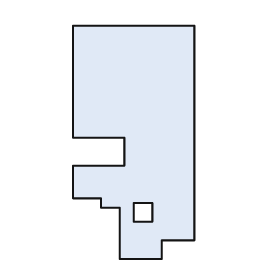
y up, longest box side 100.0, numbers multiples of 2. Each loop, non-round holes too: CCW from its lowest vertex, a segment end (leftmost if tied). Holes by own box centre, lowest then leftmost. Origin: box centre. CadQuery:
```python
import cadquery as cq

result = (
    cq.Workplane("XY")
    .moveTo(-6.0, -50.0)
    .lineTo(12.0, -50.0)
    .lineTo(12.0, -42.0)
    .lineTo(26.0, -42.0)
    .lineTo(26.0, 50.0)
    .lineTo(-26.0, 50.0)
    .lineTo(-26.0, 2.0)
    .lineTo(-4.0, 2.0)
    .lineTo(-4.0, -10.0)
    .lineTo(-26.0, -10.0)
    .lineTo(-26.0, -24.0)
    .lineTo(-14.0, -24.0)
    .lineTo(-14.0, -28.0)
    .lineTo(-6.0, -28.0)
    .close()
    .moveTo(0.0, -34.0)
    .lineTo(8.0, -34.0)
    .lineTo(8.0, -26.0)
    .lineTo(0.0, -26.0)
    .close()
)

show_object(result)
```